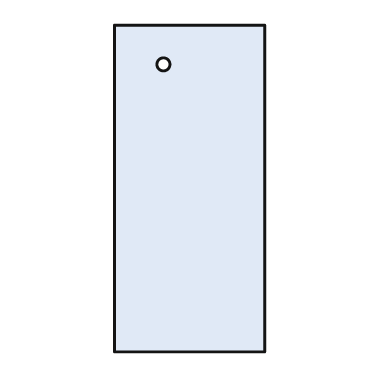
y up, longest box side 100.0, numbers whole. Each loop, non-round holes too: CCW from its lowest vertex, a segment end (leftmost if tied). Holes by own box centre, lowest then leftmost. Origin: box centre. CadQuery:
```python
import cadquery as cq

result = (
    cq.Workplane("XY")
    .moveTo(-23.0, -50.0)
    .lineTo(23.0, -50.0)
    .lineTo(23.0, 50.0)
    .lineTo(-23.0, 50.0)
    .close()
    .moveTo(-8.0, 38.0)
    .circle(2.0)
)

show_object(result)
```